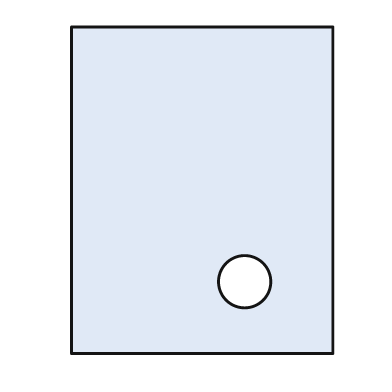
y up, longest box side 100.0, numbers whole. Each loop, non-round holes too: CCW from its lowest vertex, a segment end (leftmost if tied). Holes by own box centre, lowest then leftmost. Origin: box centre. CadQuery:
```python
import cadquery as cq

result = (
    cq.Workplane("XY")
    .moveTo(-40.0, -50.0)
    .lineTo(40.0, -50.0)
    .lineTo(40.0, 50.0)
    .lineTo(-40.0, 50.0)
    .close()
    .moveTo(13.0, -28.0)
    .circle(8.0)
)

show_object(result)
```